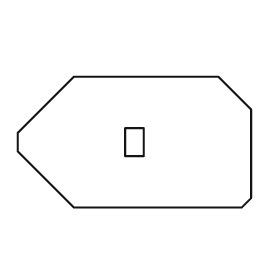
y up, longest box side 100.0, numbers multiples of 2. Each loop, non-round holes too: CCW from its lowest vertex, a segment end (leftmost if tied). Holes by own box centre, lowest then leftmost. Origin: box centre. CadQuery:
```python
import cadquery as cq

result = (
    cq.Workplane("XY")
    .moveTo(-26.0, -28.0)
    .lineTo(46.0, -28.0)
    .lineTo(50.0, -24.0)
    .lineTo(50.0, 14.0)
    .lineTo(36.0, 28.0)
    .lineTo(-26.0, 28.0)
    .lineTo(-50.0, 4.0)
    .lineTo(-50.0, -4.0)
    .close()
    .moveTo(-4.0, -6.0)
    .lineTo(4.0, -6.0)
    .lineTo(4.0, 6.0)
    .lineTo(-4.0, 6.0)
    .close()
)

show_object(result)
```